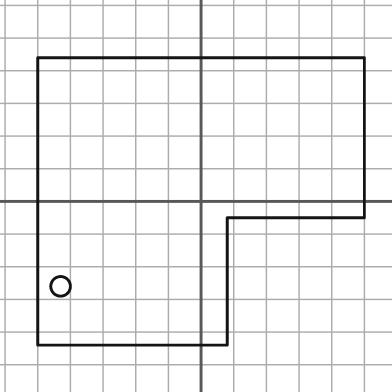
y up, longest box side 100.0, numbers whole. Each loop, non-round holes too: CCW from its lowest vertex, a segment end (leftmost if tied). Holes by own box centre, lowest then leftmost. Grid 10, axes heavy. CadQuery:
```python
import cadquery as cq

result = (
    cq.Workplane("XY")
    .moveTo(-50.0, -44.0)
    .lineTo(8.0, -44.0)
    .lineTo(8.0, -5.0)
    .lineTo(50.0, -5.0)
    .lineTo(50.0, 44.0)
    .lineTo(-50.0, 44.0)
    .close()
    .moveTo(-43.0, -26.0)
    .circle(3.0)
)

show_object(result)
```